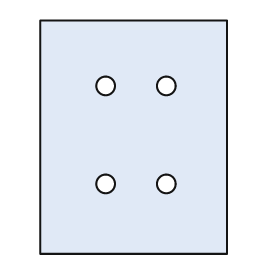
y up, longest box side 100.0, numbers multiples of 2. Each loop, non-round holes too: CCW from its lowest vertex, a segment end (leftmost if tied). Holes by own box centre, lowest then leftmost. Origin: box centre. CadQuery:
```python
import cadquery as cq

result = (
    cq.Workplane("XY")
    .moveTo(-40.0, -50.0)
    .lineTo(40.0, -50.0)
    .lineTo(40.0, 50.0)
    .lineTo(-40.0, 50.0)
    .close()
    .moveTo(-12.0, -20.0)
    .circle(4.0)
    .moveTo(14.0, -20.0)
    .circle(4.0)
    .moveTo(-12.0, 22.0)
    .circle(4.0)
    .moveTo(14.0, 22.0)
    .circle(4.0)
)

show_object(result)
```